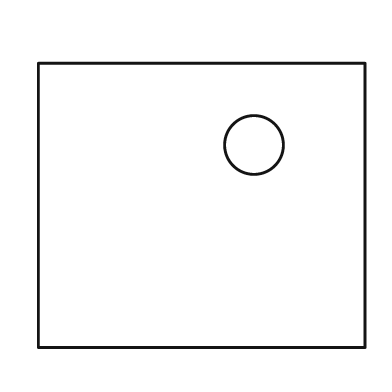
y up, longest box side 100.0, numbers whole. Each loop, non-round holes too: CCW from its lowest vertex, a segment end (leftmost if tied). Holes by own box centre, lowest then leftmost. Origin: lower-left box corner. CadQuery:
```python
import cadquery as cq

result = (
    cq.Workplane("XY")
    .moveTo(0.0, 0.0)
    .lineTo(100.0, 0.0)
    .lineTo(100.0, 87.0)
    .lineTo(0.0, 87.0)
    .close()
    .moveTo(66.0, 62.0)
    .circle(9.0)
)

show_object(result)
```